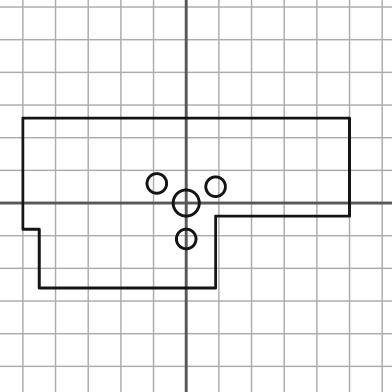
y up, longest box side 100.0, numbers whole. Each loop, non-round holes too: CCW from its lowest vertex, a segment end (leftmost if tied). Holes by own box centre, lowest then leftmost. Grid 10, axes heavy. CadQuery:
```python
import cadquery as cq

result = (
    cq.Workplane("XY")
    .moveTo(-45.0, -26.0)
    .lineTo(9.0, -26.0)
    .lineTo(9.0, -4.0)
    .lineTo(50.0, -4.0)
    .lineTo(50.0, 26.0)
    .lineTo(-50.0, 26.0)
    .lineTo(-50.0, -8.0)
    .lineTo(-45.0, -8.0)
    .close()
    .moveTo(0.0, -11.0)
    .circle(3.0)
    .moveTo(0.0, 0.0)
    .circle(4.0)
    .moveTo(9.0, 5.0)
    .circle(3.0)
    .moveTo(-9.0, 6.0)
    .circle(3.0)
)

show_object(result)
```